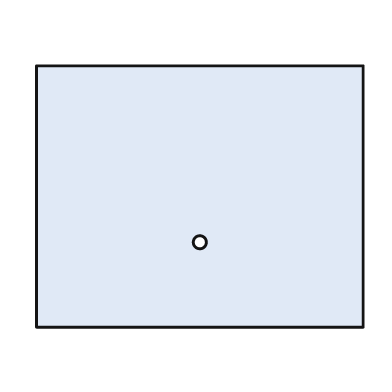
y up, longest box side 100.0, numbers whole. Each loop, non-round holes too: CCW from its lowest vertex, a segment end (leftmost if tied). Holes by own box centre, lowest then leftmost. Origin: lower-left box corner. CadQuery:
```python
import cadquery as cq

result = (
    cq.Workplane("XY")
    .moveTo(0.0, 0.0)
    .lineTo(100.0, 0.0)
    .lineTo(100.0, 80.0)
    .lineTo(0.0, 80.0)
    .close()
    .moveTo(50.0, 26.0)
    .circle(2.0)
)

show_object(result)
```